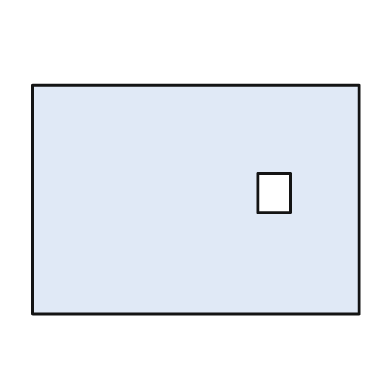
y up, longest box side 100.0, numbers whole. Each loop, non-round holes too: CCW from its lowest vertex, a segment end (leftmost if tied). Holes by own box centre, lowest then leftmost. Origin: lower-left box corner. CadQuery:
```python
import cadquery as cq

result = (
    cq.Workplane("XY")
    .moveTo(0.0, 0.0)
    .lineTo(100.0, 0.0)
    .lineTo(100.0, 70.0)
    .lineTo(0.0, 70.0)
    .close()
    .moveTo(69.0, 31.0)
    .lineTo(79.0, 31.0)
    .lineTo(79.0, 43.0)
    .lineTo(69.0, 43.0)
    .close()
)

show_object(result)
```